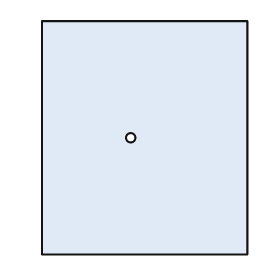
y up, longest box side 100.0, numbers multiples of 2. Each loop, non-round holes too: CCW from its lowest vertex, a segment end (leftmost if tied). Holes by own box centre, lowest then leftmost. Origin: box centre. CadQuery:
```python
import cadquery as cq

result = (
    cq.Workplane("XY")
    .moveTo(-44.0, -50.0)
    .lineTo(44.0, -50.0)
    .lineTo(44.0, 50.0)
    .lineTo(-44.0, 50.0)
    .close()
    .moveTo(-6.0, 0.0)
    .circle(2.0)
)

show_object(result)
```